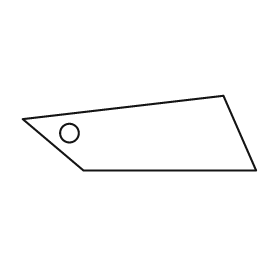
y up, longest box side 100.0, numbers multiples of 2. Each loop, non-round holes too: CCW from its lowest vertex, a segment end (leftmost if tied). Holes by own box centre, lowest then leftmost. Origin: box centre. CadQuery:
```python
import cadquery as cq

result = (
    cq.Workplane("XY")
    .moveTo(-24.0, -16.0)
    .lineTo(50.0, -16.0)
    .lineTo(36.0, 16.0)
    .lineTo(-50.0, 6.0)
    .close()
    .moveTo(-30.0, 0.0)
    .circle(4.0)
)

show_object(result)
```